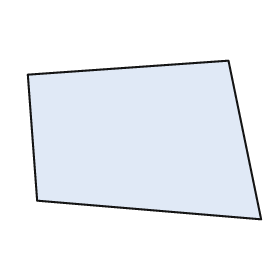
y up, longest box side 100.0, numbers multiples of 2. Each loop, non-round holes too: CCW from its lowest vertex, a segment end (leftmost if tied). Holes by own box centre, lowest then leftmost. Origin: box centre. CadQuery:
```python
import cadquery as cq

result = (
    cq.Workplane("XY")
    .moveTo(50.0, -34.0)
    .lineTo(36.0, 34.0)
    .lineTo(-50.0, 28.0)
    .lineTo(-46.0, -26.0)
    .close()
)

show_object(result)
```